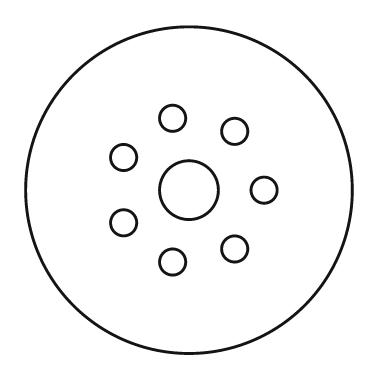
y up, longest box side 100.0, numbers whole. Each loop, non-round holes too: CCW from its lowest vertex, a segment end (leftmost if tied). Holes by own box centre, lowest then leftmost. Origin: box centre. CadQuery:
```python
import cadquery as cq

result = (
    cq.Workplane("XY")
    .moveTo(0.0, 0.0)
    .circle(50.0)
    .moveTo(-5.0, -22.0)
    .circle(4.0)
    .moveTo(14.0, -18.0)
    .circle(4.0)
    .moveTo(-20.0, -10.0)
    .circle(4.0)
    .moveTo(0.0, 0.0)
    .circle(9.0)
    .moveTo(23.0, 0.0)
    .circle(4.0)
    .moveTo(-20.0, 10.0)
    .circle(4.0)
    .moveTo(14.0, 18.0)
    .circle(4.0)
    .moveTo(-5.0, 22.0)
    .circle(4.0)
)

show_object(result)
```